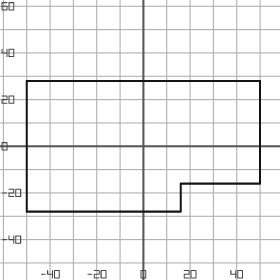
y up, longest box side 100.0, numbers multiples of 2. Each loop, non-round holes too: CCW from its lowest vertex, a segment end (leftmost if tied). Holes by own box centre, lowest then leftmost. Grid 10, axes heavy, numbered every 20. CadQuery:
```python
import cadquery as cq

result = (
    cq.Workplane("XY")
    .moveTo(-50.0, -28.0)
    .lineTo(16.0, -28.0)
    .lineTo(16.0, -16.0)
    .lineTo(50.0, -16.0)
    .lineTo(50.0, 28.0)
    .lineTo(-50.0, 28.0)
    .close()
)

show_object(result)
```